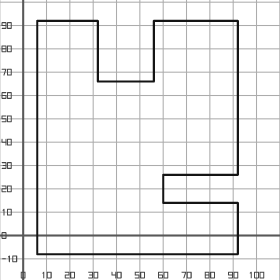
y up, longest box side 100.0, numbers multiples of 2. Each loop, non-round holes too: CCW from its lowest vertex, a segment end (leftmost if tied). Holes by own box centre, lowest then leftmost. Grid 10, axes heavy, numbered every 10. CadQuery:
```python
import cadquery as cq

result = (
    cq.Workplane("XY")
    .moveTo(6.0, -8.0)
    .lineTo(92.0, -8.0)
    .lineTo(92.0, 14.0)
    .lineTo(60.0, 14.0)
    .lineTo(60.0, 26.0)
    .lineTo(92.0, 26.0)
    .lineTo(92.0, 92.0)
    .lineTo(56.0, 92.0)
    .lineTo(56.0, 66.0)
    .lineTo(32.0, 66.0)
    .lineTo(32.0, 92.0)
    .lineTo(6.0, 92.0)
    .close()
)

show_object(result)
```